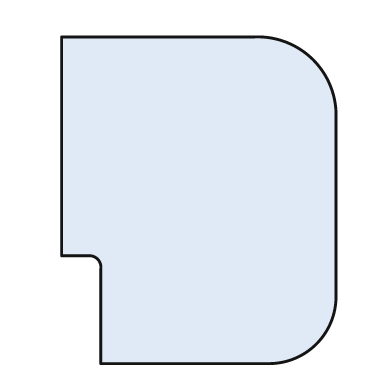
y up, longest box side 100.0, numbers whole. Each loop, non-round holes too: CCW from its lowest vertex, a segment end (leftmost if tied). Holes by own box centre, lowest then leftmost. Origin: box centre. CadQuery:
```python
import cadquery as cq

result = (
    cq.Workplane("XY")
    .moveTo(-30.0, -50.0)
    .lineTo(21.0, -50.0)
    .threePointArc((36.0, -44.0), (42.0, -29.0))
    .lineTo(42.0, 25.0)
    .threePointArc((35.0, 43.0), (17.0, 50.0))
    .lineTo(-42.0, 50.0)
    .lineTo(-42.0, -17.0)
    .lineTo(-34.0, -17.0)
    .threePointArc((-31.0, -18.0), (-30.0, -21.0))
    .close()
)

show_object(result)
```